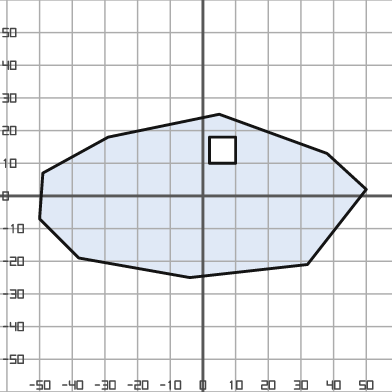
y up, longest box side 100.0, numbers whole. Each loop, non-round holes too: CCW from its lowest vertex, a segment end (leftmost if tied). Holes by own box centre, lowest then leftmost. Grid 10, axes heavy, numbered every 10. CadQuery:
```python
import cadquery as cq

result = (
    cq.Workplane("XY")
    .moveTo(-4.0, -25.0)
    .lineTo(32.0, -21.0)
    .lineTo(50.0, 2.0)
    .lineTo(38.0, 13.0)
    .lineTo(5.0, 25.0)
    .lineTo(-29.0, 18.0)
    .lineTo(-49.0, 7.0)
    .lineTo(-50.0, -7.0)
    .lineTo(-38.0, -19.0)
    .close()
    .moveTo(2.0, 10.0)
    .lineTo(10.0, 10.0)
    .lineTo(10.0, 18.0)
    .lineTo(2.0, 18.0)
    .close()
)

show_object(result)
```